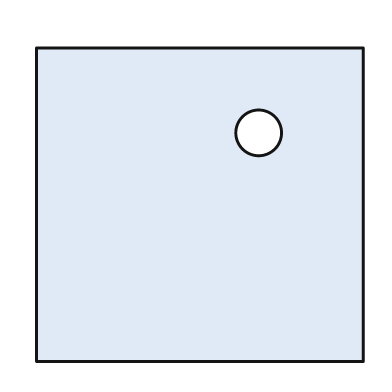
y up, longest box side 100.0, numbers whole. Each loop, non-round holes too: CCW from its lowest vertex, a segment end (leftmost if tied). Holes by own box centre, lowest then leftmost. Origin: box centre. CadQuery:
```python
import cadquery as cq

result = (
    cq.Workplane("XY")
    .moveTo(-50.0, -48.0)
    .lineTo(50.0, -48.0)
    .lineTo(50.0, 48.0)
    .lineTo(-50.0, 48.0)
    .close()
    .moveTo(18.0, 22.0)
    .circle(7.0)
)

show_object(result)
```